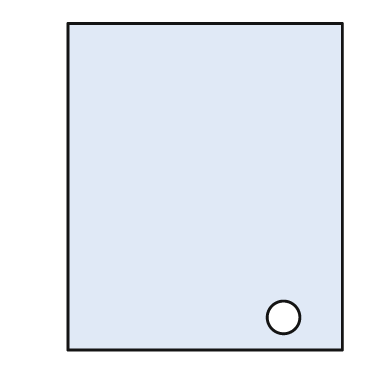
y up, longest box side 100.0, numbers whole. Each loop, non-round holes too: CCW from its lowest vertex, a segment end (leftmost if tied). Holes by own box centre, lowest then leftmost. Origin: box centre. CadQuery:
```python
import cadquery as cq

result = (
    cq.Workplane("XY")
    .moveTo(-42.0, -50.0)
    .lineTo(42.0, -50.0)
    .lineTo(42.0, 50.0)
    .lineTo(-42.0, 50.0)
    .close()
    .moveTo(24.0, -40.0)
    .circle(5.0)
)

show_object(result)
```